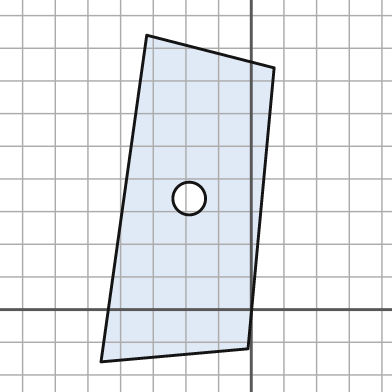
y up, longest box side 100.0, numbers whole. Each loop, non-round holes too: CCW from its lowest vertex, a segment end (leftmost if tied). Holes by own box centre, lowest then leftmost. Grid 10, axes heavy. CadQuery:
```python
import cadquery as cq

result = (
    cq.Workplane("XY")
    .moveTo(-46.0, -16.0)
    .lineTo(-1.0, -12.0)
    .lineTo(7.0, 74.0)
    .lineTo(-32.0, 84.0)
    .close()
    .moveTo(-19.0, 34.0)
    .circle(5.0)
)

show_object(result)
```